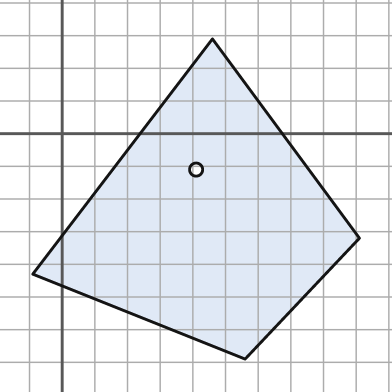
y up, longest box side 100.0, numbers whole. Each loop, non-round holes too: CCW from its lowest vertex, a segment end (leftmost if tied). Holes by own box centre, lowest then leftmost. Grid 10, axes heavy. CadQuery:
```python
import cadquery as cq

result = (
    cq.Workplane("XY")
    .moveTo(56.0, -69.0)
    .lineTo(91.0, -32.0)
    .lineTo(46.0, 29.0)
    .lineTo(-9.0, -43.0)
    .close()
    .moveTo(41.0, -11.0)
    .circle(2.0)
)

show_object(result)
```